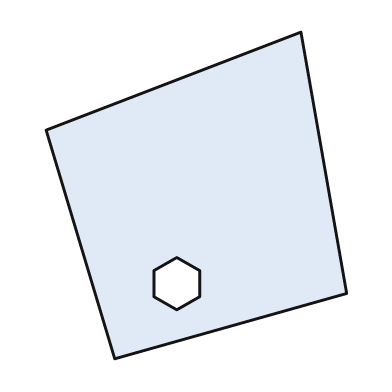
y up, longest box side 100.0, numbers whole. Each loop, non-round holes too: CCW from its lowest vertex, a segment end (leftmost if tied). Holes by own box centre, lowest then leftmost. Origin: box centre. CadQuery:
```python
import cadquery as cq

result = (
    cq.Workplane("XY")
    .moveTo(-25.0, -50.0)
    .lineTo(46.0, -30.0)
    .lineTo(32.0, 50.0)
    .lineTo(-46.0, 20.0)
    .close()
    .moveTo(-6.0, -35.0)
    .lineTo(1.0, -31.0)
    .lineTo(1.0, -23.0)
    .lineTo(-6.0, -19.0)
    .lineTo(-13.0, -23.0)
    .lineTo(-13.0, -31.0)
    .close()
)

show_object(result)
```